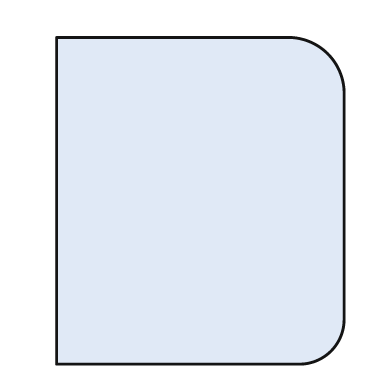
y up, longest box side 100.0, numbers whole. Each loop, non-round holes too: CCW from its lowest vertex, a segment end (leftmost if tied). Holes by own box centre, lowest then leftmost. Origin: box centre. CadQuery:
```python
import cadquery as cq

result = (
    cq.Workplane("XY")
    .moveTo(-44.0, -50.0)
    .lineTo(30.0, -50.0)
    .threePointArc((40.0, -46.0), (44.0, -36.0))
    .lineTo(44.0, 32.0)
    .threePointArc((39.0, 45.0), (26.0, 50.0))
    .lineTo(-44.0, 50.0)
    .close()
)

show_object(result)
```